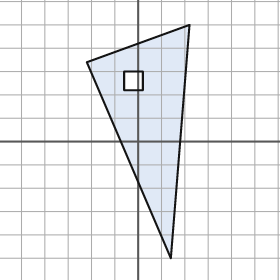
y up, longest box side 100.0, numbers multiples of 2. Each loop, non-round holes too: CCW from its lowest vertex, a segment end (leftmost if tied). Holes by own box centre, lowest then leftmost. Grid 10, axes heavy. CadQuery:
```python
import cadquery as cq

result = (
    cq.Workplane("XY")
    .moveTo(14.0, -50.0)
    .lineTo(22.0, 50.0)
    .lineTo(-22.0, 34.0)
    .close()
    .moveTo(-6.0, 22.0)
    .lineTo(2.0, 22.0)
    .lineTo(2.0, 30.0)
    .lineTo(-6.0, 30.0)
    .close()
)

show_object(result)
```